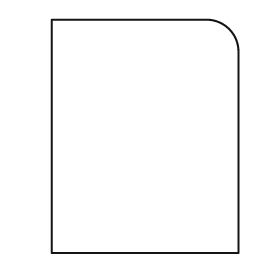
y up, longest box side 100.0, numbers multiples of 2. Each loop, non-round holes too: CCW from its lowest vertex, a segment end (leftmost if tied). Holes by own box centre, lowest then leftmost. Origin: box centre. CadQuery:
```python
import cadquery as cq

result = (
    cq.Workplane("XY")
    .moveTo(-40.0, -50.0)
    .lineTo(40.0, -50.0)
    .lineTo(40.0, 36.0)
    .threePointArc((36.0, 46.0), (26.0, 50.0))
    .lineTo(-40.0, 50.0)
    .close()
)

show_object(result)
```